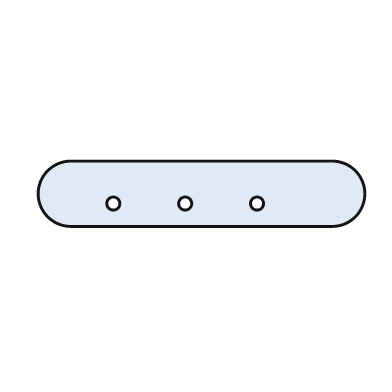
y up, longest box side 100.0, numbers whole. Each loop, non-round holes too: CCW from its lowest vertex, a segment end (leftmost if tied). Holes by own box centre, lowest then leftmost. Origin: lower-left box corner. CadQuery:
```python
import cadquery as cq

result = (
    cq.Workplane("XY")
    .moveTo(10.0, 0.0)
    .lineTo(90.0, 0.0)
    .threePointArc((100.0, 10.0), (90.0, 20.0))
    .lineTo(10.0, 20.0)
    .threePointArc((0.0, 10.0), (10.0, 0.0))
    .close()
    .moveTo(23.0, 7.0)
    .circle(2.0)
    .moveTo(45.0, 7.0)
    .circle(2.0)
    .moveTo(67.0, 7.0)
    .circle(2.0)
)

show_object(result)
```